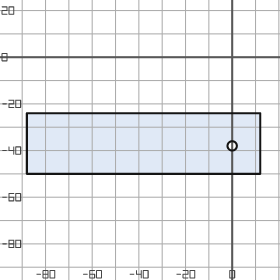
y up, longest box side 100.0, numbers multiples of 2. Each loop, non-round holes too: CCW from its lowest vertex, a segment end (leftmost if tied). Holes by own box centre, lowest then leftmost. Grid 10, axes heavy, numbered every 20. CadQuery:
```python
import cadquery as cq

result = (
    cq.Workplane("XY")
    .moveTo(-88.0, -50.0)
    .lineTo(12.0, -50.0)
    .lineTo(12.0, -24.0)
    .lineTo(-88.0, -24.0)
    .close()
    .moveTo(0.0, -38.0)
    .circle(2.0)
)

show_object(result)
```